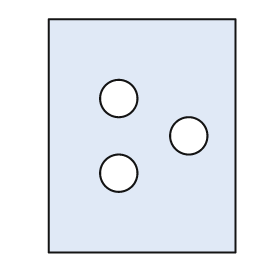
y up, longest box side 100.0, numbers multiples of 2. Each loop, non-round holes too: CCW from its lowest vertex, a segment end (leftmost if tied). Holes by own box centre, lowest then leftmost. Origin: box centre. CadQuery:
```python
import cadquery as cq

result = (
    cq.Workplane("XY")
    .moveTo(-40.0, -50.0)
    .lineTo(40.0, -50.0)
    .lineTo(40.0, 50.0)
    .lineTo(-40.0, 50.0)
    .close()
    .moveTo(-10.0, -16.0)
    .circle(8.0)
    .moveTo(20.0, 0.0)
    .circle(8.0)
    .moveTo(-10.0, 16.0)
    .circle(8.0)
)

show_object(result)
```